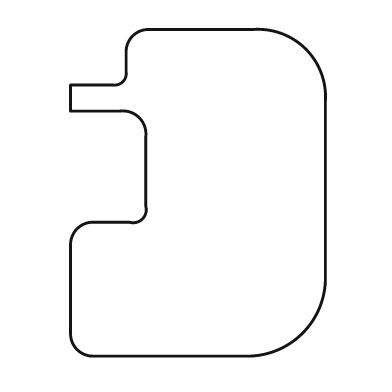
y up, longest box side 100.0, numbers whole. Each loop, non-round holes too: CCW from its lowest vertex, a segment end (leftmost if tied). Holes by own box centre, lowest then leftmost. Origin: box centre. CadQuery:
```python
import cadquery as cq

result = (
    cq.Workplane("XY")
    .moveTo(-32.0, -50.0)
    .lineTo(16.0, -50.0)
    .threePointArc((32.0, -43.0), (39.0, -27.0))
    .lineTo(39.0, 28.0)
    .threePointArc((33.0, 44.0), (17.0, 50.0))
    .lineTo(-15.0, 50.0)
    .threePointArc((-20.0, 48.0), (-22.0, 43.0))
    .lineTo(-22.0, 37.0)
    .threePointArc((-23.0, 34.0), (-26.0, 33.0))
    .lineTo(-39.0, 33.0)
    .lineTo(-39.0, 25.0)
    .lineTo(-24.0, 25.0)
    .threePointArc((-18.0, 23.0), (-16.0, 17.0))
    .lineTo(-16.0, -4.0)
    .threePointArc((-17.0, -8.0), (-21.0, -9.0))
    .lineTo(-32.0, -9.0)
    .threePointArc((-37.0, -11.0), (-39.0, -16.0))
    .lineTo(-39.0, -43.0)
    .threePointArc((-37.0, -48.0), (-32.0, -50.0))
    .close()
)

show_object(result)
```